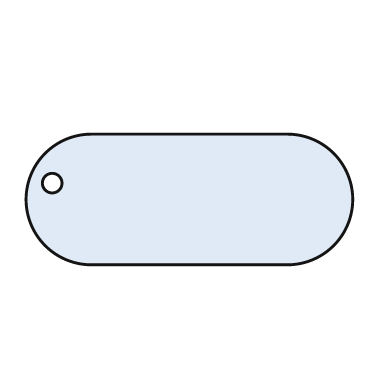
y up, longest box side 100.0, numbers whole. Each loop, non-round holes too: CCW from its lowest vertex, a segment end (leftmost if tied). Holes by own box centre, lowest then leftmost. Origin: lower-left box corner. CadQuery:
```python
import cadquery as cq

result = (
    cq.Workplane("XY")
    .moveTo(20.0, 0.0)
    .lineTo(80.0, 0.0)
    .threePointArc((100.0, 20.0), (80.0, 40.0))
    .lineTo(20.0, 40.0)
    .threePointArc((0.0, 20.0), (20.0, 0.0))
    .close()
    .moveTo(8.0, 25.0)
    .circle(3.0)
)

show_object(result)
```